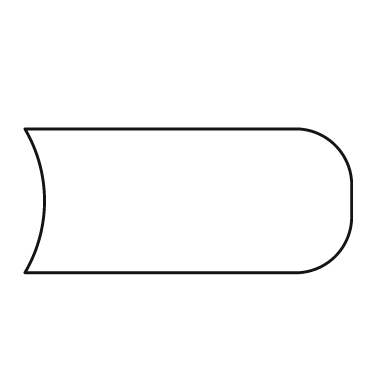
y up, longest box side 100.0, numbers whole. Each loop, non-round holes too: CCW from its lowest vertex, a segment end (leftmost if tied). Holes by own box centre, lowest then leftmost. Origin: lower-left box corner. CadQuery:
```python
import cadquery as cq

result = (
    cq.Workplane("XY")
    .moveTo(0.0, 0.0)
    .lineTo(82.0, 0.0)
    .threePointArc((95.0, 5.0), (100.0, 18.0))
    .lineTo(100.0, 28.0)
    .threePointArc((95.0, 39.0), (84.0, 44.0))
    .lineTo(0.0, 44.0)
    .threePointArc((6.0, 22.0), (0.0, 0.0))
    .close()
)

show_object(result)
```